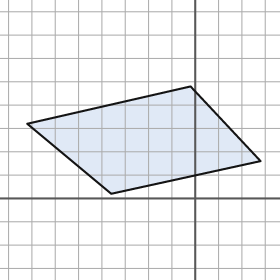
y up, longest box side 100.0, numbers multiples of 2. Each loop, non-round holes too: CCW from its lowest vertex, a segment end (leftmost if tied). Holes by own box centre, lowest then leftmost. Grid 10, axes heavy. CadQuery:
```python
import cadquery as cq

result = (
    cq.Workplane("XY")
    .moveTo(-36.0, 2.0)
    .lineTo(28.0, 16.0)
    .lineTo(-2.0, 48.0)
    .lineTo(-72.0, 32.0)
    .close()
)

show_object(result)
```